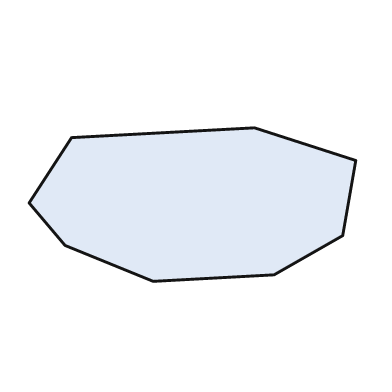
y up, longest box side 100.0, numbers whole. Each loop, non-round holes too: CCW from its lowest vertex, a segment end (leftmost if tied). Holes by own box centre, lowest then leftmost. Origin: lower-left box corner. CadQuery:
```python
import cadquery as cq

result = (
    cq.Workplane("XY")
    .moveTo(38.0, 0.0)
    .lineTo(75.0, 2.0)
    .lineTo(96.0, 14.0)
    .lineTo(100.0, 37.0)
    .lineTo(69.0, 47.0)
    .lineTo(13.0, 44.0)
    .lineTo(0.0, 24.0)
    .lineTo(11.0, 11.0)
    .close()
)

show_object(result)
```